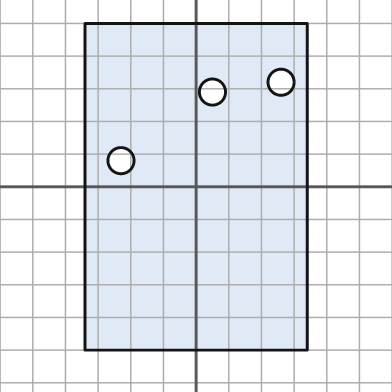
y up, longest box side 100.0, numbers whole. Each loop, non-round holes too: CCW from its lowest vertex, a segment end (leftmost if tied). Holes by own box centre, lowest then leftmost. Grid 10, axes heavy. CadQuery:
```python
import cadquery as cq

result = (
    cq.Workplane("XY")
    .moveTo(-34.0, -50.0)
    .lineTo(34.0, -50.0)
    .lineTo(34.0, 50.0)
    .lineTo(-34.0, 50.0)
    .close()
    .moveTo(-23.0, 8.0)
    .circle(4.0)
    .moveTo(5.0, 29.0)
    .circle(4.0)
    .moveTo(26.0, 32.0)
    .circle(4.0)
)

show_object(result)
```